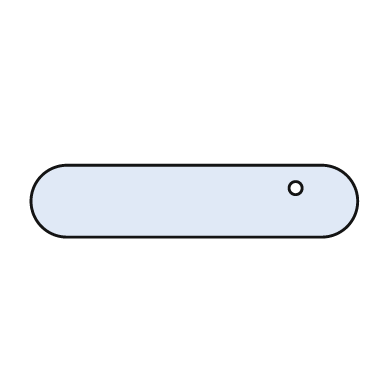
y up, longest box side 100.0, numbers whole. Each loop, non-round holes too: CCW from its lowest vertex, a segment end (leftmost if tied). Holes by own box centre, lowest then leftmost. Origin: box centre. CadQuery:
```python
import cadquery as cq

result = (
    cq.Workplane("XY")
    .moveTo(-39.0, -11.0)
    .lineTo(39.0, -11.0)
    .threePointArc((50.0, 0.0), (39.0, 11.0))
    .lineTo(-39.0, 11.0)
    .threePointArc((-50.0, 0.0), (-39.0, -11.0))
    .close()
    .moveTo(31.0, 4.0)
    .circle(2.0)
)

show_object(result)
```